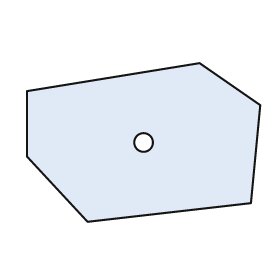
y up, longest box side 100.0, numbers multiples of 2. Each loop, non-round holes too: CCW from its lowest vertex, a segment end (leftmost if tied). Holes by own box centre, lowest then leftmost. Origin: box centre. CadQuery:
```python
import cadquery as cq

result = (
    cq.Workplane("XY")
    .moveTo(-24.0, -34.0)
    .lineTo(46.0, -26.0)
    .lineTo(50.0, 16.0)
    .lineTo(24.0, 34.0)
    .lineTo(-50.0, 22.0)
    .lineTo(-50.0, -6.0)
    .close()
    .moveTo(0.0, 0.0)
    .circle(4.0)
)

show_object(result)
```